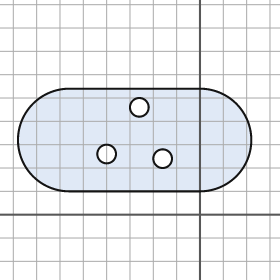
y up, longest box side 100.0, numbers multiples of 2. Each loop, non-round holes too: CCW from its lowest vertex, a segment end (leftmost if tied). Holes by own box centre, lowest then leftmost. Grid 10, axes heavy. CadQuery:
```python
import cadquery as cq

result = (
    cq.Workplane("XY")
    .moveTo(-56.0, 10.0)
    .lineTo(0.0, 10.0)
    .threePointArc((22.0, 32.0), (0.0, 54.0))
    .lineTo(-56.0, 54.0)
    .threePointArc((-78.0, 32.0), (-56.0, 10.0))
    .close()
    .moveTo(-16.0, 24.0)
    .circle(4.0)
    .moveTo(-40.0, 26.0)
    .circle(4.0)
    .moveTo(-26.0, 46.0)
    .circle(4.0)
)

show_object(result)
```